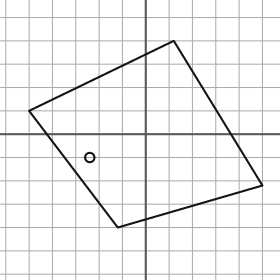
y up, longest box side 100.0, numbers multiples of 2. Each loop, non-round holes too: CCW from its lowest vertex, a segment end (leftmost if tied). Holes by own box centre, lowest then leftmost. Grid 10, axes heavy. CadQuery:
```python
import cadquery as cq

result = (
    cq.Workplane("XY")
    .moveTo(-12.0, -40.0)
    .lineTo(50.0, -22.0)
    .lineTo(12.0, 40.0)
    .lineTo(-50.0, 10.0)
    .close()
    .moveTo(-24.0, -10.0)
    .circle(2.0)
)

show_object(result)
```